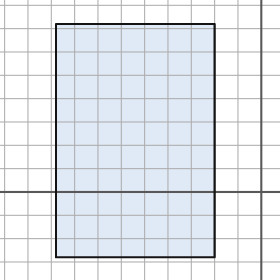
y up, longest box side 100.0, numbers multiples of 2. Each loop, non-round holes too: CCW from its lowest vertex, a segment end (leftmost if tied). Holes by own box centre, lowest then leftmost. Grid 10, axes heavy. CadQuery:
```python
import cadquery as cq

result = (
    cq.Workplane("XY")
    .moveTo(-88.0, -28.0)
    .lineTo(-20.0, -28.0)
    .lineTo(-20.0, 72.0)
    .lineTo(-88.0, 72.0)
    .close()
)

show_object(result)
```